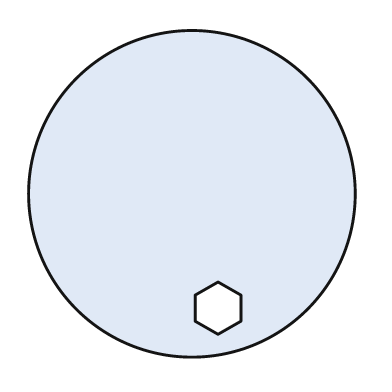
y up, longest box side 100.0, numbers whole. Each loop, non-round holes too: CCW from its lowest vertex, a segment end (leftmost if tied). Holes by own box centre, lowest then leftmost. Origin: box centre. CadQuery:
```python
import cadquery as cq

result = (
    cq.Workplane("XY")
    .moveTo(0.0, 0.0)
    .circle(50.0)
    .moveTo(8.0, -43.0)
    .lineTo(15.0, -39.0)
    .lineTo(15.0, -31.0)
    .lineTo(8.0, -27.0)
    .lineTo(1.0, -31.0)
    .lineTo(1.0, -39.0)
    .close()
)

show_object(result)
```